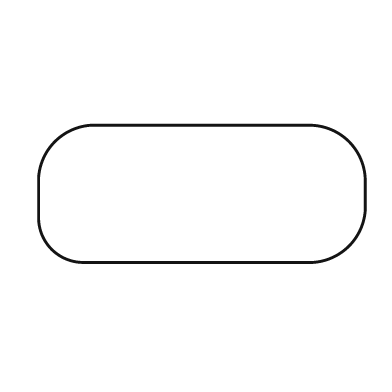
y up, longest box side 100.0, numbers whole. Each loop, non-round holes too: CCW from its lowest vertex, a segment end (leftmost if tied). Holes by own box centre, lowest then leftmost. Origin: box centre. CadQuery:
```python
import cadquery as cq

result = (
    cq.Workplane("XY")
    .moveTo(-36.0, -21.0)
    .lineTo(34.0, -21.0)
    .threePointArc((45.0, -16.0), (50.0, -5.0))
    .lineTo(50.0, 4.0)
    .threePointArc((45.0, 16.0), (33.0, 21.0))
    .lineTo(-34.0, 21.0)
    .threePointArc((-45.0, 16.0), (-50.0, 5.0))
    .lineTo(-50.0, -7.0)
    .threePointArc((-46.0, -17.0), (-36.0, -21.0))
    .close()
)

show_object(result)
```